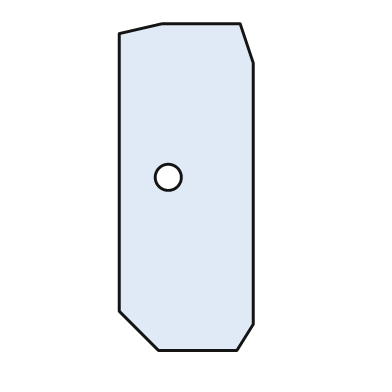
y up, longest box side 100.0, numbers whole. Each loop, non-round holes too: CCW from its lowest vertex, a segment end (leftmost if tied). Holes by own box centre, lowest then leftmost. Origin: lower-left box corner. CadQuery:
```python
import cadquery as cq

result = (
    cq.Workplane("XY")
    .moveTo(12.0, 0.0)
    .lineTo(36.0, 0.0)
    .lineTo(41.0, 8.0)
    .lineTo(41.0, 88.0)
    .lineTo(37.0, 100.0)
    .lineTo(13.0, 100.0)
    .lineTo(0.0, 97.0)
    .lineTo(0.0, 12.0)
    .close()
    .moveTo(15.0, 53.0)
    .circle(4.0)
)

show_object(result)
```